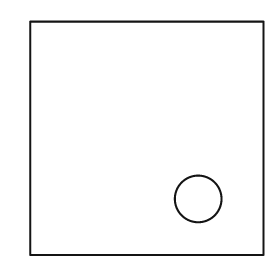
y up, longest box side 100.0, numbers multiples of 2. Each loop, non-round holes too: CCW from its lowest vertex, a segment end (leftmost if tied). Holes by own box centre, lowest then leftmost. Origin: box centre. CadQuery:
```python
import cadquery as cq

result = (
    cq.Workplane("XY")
    .moveTo(-50.0, -50.0)
    .lineTo(50.0, -50.0)
    .lineTo(50.0, 50.0)
    .lineTo(-50.0, 50.0)
    .close()
    .moveTo(22.0, -26.0)
    .circle(10.0)
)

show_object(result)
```